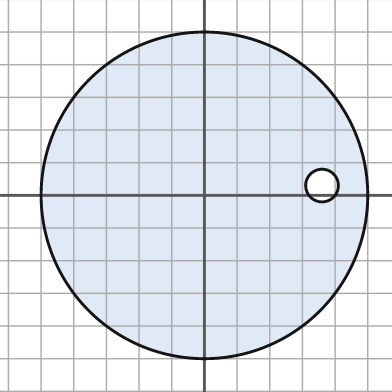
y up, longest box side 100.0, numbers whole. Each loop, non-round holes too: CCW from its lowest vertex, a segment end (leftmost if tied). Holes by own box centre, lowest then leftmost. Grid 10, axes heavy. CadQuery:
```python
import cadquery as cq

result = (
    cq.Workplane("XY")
    .moveTo(0.0, 0.0)
    .circle(50.0)
    .moveTo(36.0, 3.0)
    .circle(5.0)
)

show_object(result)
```